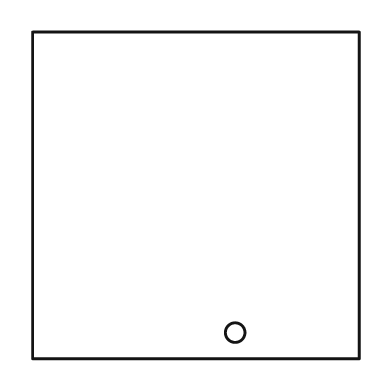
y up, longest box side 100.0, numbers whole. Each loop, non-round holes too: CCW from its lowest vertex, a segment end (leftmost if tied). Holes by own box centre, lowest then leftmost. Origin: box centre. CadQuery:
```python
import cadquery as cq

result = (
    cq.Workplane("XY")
    .moveTo(-50.0, -50.0)
    .lineTo(50.0, -50.0)
    .lineTo(50.0, 50.0)
    .lineTo(-50.0, 50.0)
    .close()
    .moveTo(12.0, -42.0)
    .circle(3.0)
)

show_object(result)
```